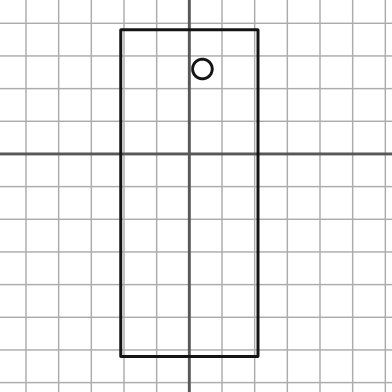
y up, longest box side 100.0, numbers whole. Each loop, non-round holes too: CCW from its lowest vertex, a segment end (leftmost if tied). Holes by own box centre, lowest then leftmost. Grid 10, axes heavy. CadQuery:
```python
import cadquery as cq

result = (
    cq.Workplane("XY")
    .moveTo(-21.0, -62.0)
    .lineTo(21.0, -62.0)
    .lineTo(21.0, 38.0)
    .lineTo(-21.0, 38.0)
    .close()
    .moveTo(4.0, 26.0)
    .circle(3.0)
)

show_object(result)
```